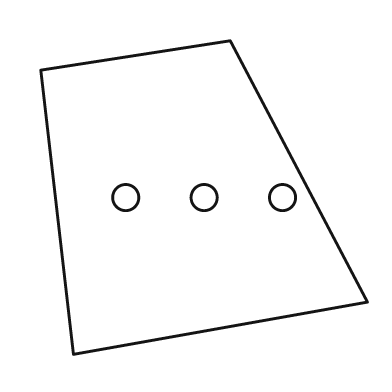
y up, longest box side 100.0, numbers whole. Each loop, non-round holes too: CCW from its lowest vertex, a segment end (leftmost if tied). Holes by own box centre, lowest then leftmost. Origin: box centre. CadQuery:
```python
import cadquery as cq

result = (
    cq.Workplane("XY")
    .moveTo(-40.0, -48.0)
    .lineTo(50.0, -32.0)
    .lineTo(8.0, 48.0)
    .lineTo(-50.0, 39.0)
    .close()
    .moveTo(-24.0, 0.0)
    .circle(4.0)
    .moveTo(0.0, 0.0)
    .circle(4.0)
    .moveTo(24.0, 0.0)
    .circle(4.0)
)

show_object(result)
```